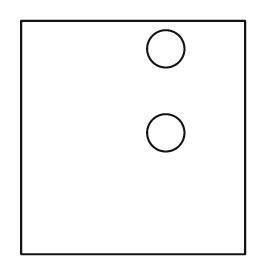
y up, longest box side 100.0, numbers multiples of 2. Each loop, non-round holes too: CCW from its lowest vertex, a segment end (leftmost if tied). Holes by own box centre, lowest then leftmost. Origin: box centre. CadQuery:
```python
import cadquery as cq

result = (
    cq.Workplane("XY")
    .moveTo(-48.0, -50.0)
    .lineTo(48.0, -50.0)
    .lineTo(48.0, 50.0)
    .lineTo(-48.0, 50.0)
    .close()
    .moveTo(14.0, 2.0)
    .circle(8.0)
    .moveTo(14.0, 38.0)
    .circle(8.0)
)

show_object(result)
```